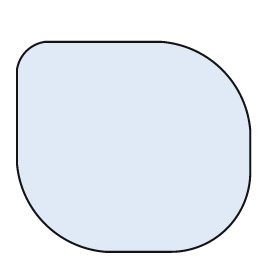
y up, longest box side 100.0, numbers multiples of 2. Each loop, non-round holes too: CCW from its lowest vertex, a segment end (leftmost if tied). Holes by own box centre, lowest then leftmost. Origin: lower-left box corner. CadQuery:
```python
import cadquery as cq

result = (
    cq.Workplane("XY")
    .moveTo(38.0, 0.0)
    .lineTo(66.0, 0.0)
    .threePointArc((90.0, 10.0), (100.0, 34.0))
    .lineTo(100.0, 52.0)
    .threePointArc((88.0, 78.0), (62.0, 90.0))
    .lineTo(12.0, 90.0)
    .threePointArc((4.0, 86.0), (0.0, 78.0))
    .lineTo(0.0, 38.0)
    .threePointArc((12.0, 12.0), (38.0, 0.0))
    .close()
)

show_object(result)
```